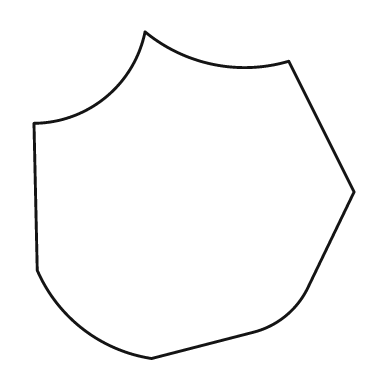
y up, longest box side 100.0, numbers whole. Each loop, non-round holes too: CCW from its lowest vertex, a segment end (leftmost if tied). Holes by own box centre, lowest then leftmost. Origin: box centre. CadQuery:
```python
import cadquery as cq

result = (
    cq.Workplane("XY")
    .moveTo(-13.0, -50.0)
    .lineTo(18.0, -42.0)
    .threePointArc((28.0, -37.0), (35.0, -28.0))
    .lineTo(49.0, 1.0)
    .lineTo(29.0, 41.0)
    .threePointArc((6.0, 40.0), (-15.0, 50.0))
    .threePointArc((-27.0, 30.0), (-49.0, 22.0))
    .lineTo(-48.0, -23.0)
    .threePointArc((-34.0, -41.0), (-13.0, -50.0))
    .close()
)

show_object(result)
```